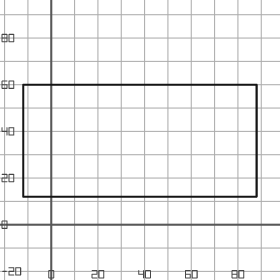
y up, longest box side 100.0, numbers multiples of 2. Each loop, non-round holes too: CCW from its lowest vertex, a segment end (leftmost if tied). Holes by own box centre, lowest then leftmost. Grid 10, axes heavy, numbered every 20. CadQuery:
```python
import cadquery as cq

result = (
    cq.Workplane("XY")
    .moveTo(-12.0, 12.0)
    .lineTo(88.0, 12.0)
    .lineTo(88.0, 60.0)
    .lineTo(-12.0, 60.0)
    .close()
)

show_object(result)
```